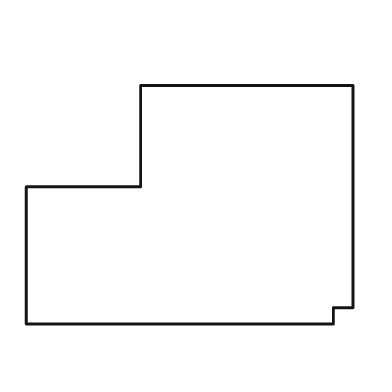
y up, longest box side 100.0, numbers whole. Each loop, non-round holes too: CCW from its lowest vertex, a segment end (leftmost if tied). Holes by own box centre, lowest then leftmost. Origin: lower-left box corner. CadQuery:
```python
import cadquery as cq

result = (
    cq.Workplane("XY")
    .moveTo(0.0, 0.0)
    .lineTo(94.0, 0.0)
    .lineTo(94.0, 5.0)
    .lineTo(100.0, 5.0)
    .lineTo(100.0, 73.0)
    .lineTo(35.0, 73.0)
    .lineTo(35.0, 42.0)
    .lineTo(0.0, 42.0)
    .close()
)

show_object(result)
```